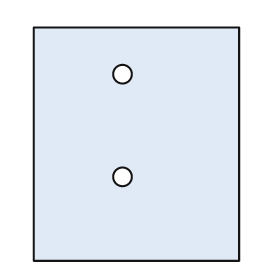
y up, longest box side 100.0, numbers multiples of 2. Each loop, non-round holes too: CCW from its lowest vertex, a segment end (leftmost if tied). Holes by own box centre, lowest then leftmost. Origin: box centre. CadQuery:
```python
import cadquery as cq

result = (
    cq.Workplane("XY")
    .moveTo(-44.0, -50.0)
    .lineTo(44.0, -50.0)
    .lineTo(44.0, 50.0)
    .lineTo(-44.0, 50.0)
    .close()
    .moveTo(-6.0, -14.0)
    .circle(4.0)
    .moveTo(-6.0, 30.0)
    .circle(4.0)
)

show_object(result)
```